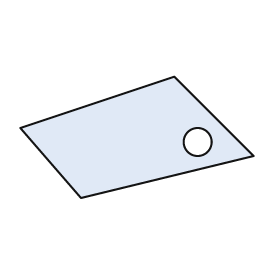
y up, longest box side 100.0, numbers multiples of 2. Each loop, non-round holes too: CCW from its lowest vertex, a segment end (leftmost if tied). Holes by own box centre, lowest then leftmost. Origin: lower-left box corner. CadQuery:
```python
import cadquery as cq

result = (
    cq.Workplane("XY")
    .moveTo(26.0, 0.0)
    .lineTo(100.0, 18.0)
    .lineTo(66.0, 52.0)
    .lineTo(0.0, 30.0)
    .close()
    .moveTo(76.0, 24.0)
    .circle(6.0)
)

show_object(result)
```